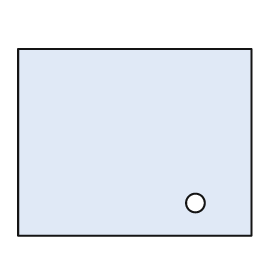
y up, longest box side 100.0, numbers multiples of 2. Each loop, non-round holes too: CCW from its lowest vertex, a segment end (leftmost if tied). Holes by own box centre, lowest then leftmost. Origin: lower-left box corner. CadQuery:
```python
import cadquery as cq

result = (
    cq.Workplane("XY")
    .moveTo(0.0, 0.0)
    .lineTo(100.0, 0.0)
    .lineTo(100.0, 80.0)
    .lineTo(0.0, 80.0)
    .close()
    .moveTo(76.0, 14.0)
    .circle(4.0)
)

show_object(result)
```